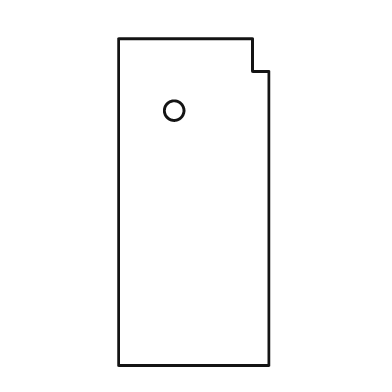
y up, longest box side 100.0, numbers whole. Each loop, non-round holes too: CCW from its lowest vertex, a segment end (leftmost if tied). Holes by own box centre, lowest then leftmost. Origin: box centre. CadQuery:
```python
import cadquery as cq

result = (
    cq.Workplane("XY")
    .moveTo(-23.0, -50.0)
    .lineTo(23.0, -50.0)
    .lineTo(23.0, 40.0)
    .lineTo(18.0, 40.0)
    .lineTo(18.0, 50.0)
    .lineTo(-23.0, 50.0)
    .close()
    .moveTo(-6.0, 28.0)
    .circle(3.0)
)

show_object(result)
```